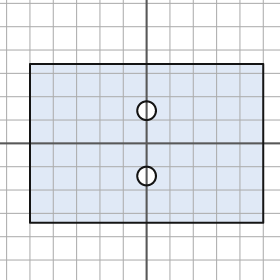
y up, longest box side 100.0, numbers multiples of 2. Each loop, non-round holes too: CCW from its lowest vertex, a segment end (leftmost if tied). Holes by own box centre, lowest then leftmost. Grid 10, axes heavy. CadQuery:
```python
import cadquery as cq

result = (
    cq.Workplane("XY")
    .moveTo(-50.0, -34.0)
    .lineTo(50.0, -34.0)
    .lineTo(50.0, 34.0)
    .lineTo(-50.0, 34.0)
    .close()
    .moveTo(0.0, -14.0)
    .circle(4.0)
    .moveTo(0.0, 14.0)
    .circle(4.0)
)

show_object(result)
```